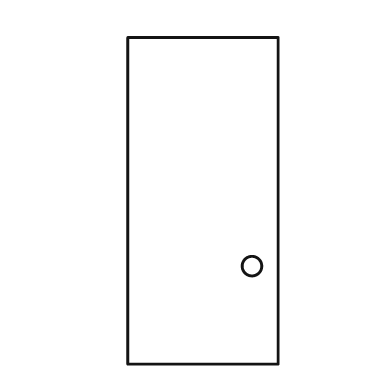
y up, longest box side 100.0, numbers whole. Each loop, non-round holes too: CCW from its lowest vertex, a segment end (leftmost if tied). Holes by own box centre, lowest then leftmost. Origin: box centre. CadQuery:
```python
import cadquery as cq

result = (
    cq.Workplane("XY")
    .moveTo(-23.0, -50.0)
    .lineTo(23.0, -50.0)
    .lineTo(23.0, 50.0)
    .lineTo(-23.0, 50.0)
    .close()
    .moveTo(15.0, -20.0)
    .circle(3.0)
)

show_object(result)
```